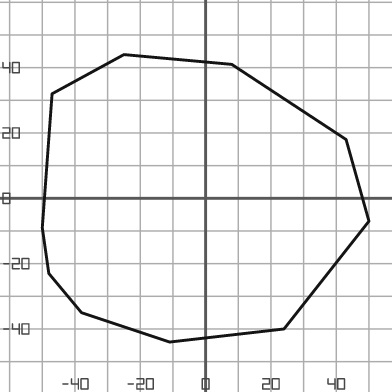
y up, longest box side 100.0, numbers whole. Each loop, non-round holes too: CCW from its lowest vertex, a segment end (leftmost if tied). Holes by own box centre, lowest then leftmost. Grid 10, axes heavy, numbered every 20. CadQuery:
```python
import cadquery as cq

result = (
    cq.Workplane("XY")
    .moveTo(-11.0, -44.0)
    .lineTo(24.0, -40.0)
    .lineTo(50.0, -7.0)
    .lineTo(43.0, 18.0)
    .lineTo(8.0, 41.0)
    .lineTo(-25.0, 44.0)
    .lineTo(-47.0, 32.0)
    .lineTo(-50.0, -9.0)
    .lineTo(-48.0, -23.0)
    .lineTo(-38.0, -35.0)
    .close()
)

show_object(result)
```